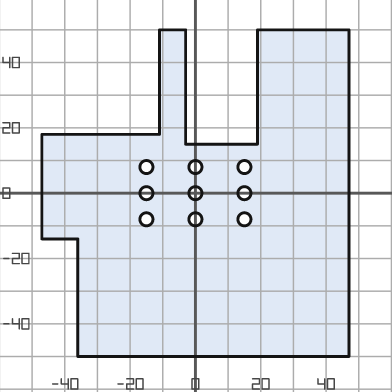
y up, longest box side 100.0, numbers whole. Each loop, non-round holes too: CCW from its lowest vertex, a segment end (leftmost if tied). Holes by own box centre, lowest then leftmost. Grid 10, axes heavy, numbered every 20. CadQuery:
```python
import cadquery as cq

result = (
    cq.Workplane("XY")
    .moveTo(-36.0, -50.0)
    .lineTo(47.0, -50.0)
    .lineTo(47.0, 50.0)
    .lineTo(19.0, 50.0)
    .lineTo(19.0, 15.0)
    .lineTo(-3.0, 15.0)
    .lineTo(-3.0, 50.0)
    .lineTo(-11.0, 50.0)
    .lineTo(-11.0, 18.0)
    .lineTo(-47.0, 18.0)
    .lineTo(-47.0, -14.0)
    .lineTo(-36.0, -14.0)
    .close()
    .moveTo(-15.0, -8.0)
    .circle(2.0)
    .moveTo(0.0, -8.0)
    .circle(2.0)
    .moveTo(15.0, -8.0)
    .circle(2.0)
    .moveTo(-15.0, 0.0)
    .circle(2.0)
    .moveTo(0.0, 0.0)
    .circle(2.0)
    .moveTo(15.0, 0.0)
    .circle(2.0)
    .moveTo(-15.0, 8.0)
    .circle(2.0)
    .moveTo(0.0, 8.0)
    .circle(2.0)
    .moveTo(15.0, 8.0)
    .circle(2.0)
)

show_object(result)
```